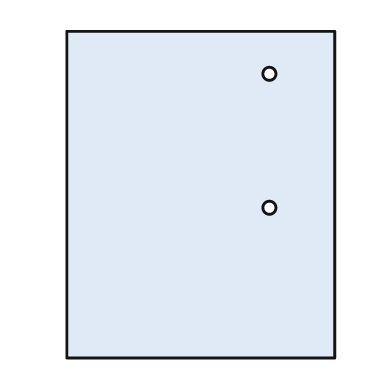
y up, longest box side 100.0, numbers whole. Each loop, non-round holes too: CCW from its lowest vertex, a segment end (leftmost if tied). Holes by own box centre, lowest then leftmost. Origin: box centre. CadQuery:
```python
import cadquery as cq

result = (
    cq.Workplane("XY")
    .moveTo(-41.0, -50.0)
    .lineTo(41.0, -50.0)
    .lineTo(41.0, 50.0)
    .lineTo(-41.0, 50.0)
    .close()
    .moveTo(21.0, -4.0)
    .circle(2.0)
    .moveTo(21.0, 37.0)
    .circle(2.0)
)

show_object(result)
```